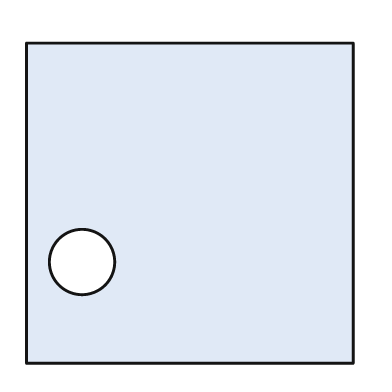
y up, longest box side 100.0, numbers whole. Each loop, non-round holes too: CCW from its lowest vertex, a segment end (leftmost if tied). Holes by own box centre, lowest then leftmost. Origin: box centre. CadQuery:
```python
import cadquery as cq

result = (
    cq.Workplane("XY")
    .moveTo(-50.0, -49.0)
    .lineTo(50.0, -49.0)
    .lineTo(50.0, 49.0)
    .lineTo(-50.0, 49.0)
    .close()
    .moveTo(-33.0, -18.0)
    .circle(10.0)
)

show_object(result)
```